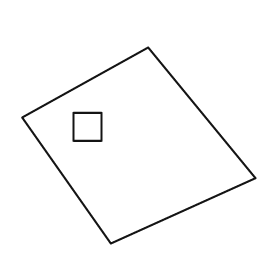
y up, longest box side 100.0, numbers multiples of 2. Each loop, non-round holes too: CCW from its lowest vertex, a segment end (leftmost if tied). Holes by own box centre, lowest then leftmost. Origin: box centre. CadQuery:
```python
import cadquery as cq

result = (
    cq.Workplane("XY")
    .moveTo(-12.0, -42.0)
    .lineTo(50.0, -14.0)
    .lineTo(4.0, 42.0)
    .lineTo(-50.0, 12.0)
    .close()
    .moveTo(-28.0, 2.0)
    .lineTo(-16.0, 2.0)
    .lineTo(-16.0, 14.0)
    .lineTo(-28.0, 14.0)
    .close()
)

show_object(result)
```